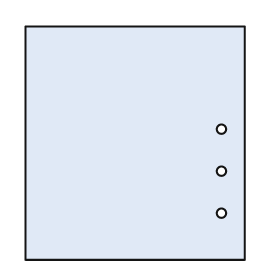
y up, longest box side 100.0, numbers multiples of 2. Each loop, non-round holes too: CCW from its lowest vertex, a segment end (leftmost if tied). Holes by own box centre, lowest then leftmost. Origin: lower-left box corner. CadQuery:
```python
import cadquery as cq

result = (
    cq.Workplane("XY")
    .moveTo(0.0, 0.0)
    .lineTo(94.0, 0.0)
    .lineTo(94.0, 100.0)
    .lineTo(0.0, 100.0)
    .close()
    .moveTo(84.0, 20.0)
    .circle(2.0)
    .moveTo(84.0, 38.0)
    .circle(2.0)
    .moveTo(84.0, 56.0)
    .circle(2.0)
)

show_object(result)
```